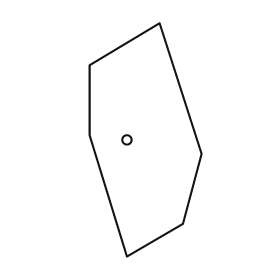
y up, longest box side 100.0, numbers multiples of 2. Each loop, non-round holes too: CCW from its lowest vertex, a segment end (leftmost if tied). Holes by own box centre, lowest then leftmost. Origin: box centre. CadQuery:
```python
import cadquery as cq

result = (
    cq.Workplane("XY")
    .moveTo(-8.0, -50.0)
    .lineTo(16.0, -36.0)
    .lineTo(24.0, -6.0)
    .lineTo(6.0, 50.0)
    .lineTo(-24.0, 32.0)
    .lineTo(-24.0, 2.0)
    .close()
    .moveTo(-8.0, 0.0)
    .circle(2.0)
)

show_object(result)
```